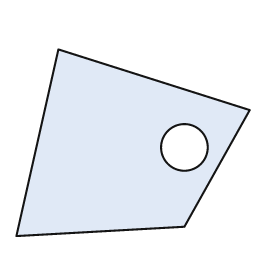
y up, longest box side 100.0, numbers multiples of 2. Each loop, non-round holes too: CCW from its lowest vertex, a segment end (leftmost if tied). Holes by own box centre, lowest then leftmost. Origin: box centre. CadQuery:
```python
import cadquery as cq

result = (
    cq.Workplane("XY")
    .moveTo(-50.0, -40.0)
    .lineTo(22.0, -36.0)
    .lineTo(50.0, 14.0)
    .lineTo(-32.0, 40.0)
    .close()
    .moveTo(22.0, -2.0)
    .circle(10.0)
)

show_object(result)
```